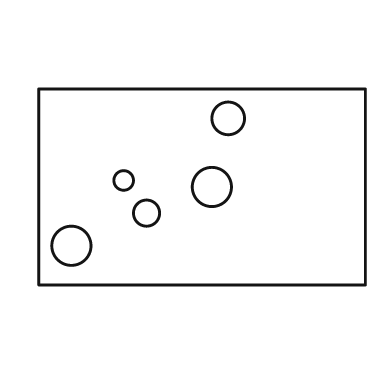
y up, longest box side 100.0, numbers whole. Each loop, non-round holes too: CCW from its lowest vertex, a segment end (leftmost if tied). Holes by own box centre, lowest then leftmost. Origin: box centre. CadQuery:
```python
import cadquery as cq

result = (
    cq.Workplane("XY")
    .moveTo(-50.0, -30.0)
    .lineTo(50.0, -30.0)
    .lineTo(50.0, 30.0)
    .lineTo(-50.0, 30.0)
    .close()
    .moveTo(-40.0, -18.0)
    .circle(6.0)
    .moveTo(-17.0, -8.0)
    .circle(4.0)
    .moveTo(3.0, 0.0)
    .circle(6.0)
    .moveTo(-24.0, 2.0)
    .circle(3.0)
    .moveTo(8.0, 21.0)
    .circle(5.0)
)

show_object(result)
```